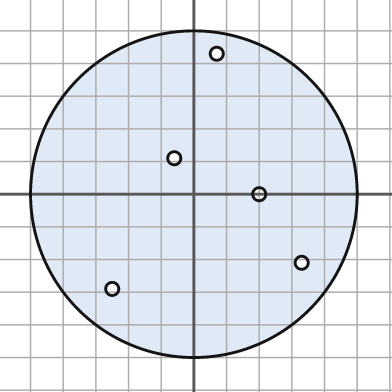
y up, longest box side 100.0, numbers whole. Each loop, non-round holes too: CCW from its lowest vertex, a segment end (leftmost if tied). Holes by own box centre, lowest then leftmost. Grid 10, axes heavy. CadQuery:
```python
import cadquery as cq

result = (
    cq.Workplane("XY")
    .moveTo(0.0, 0.0)
    .circle(50.0)
    .moveTo(-25.0, -29.0)
    .circle(2.0)
    .moveTo(33.0, -21.0)
    .circle(2.0)
    .moveTo(20.0, 0.0)
    .circle(2.0)
    .moveTo(-6.0, 11.0)
    .circle(2.0)
    .moveTo(7.0, 43.0)
    .circle(2.0)
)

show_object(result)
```